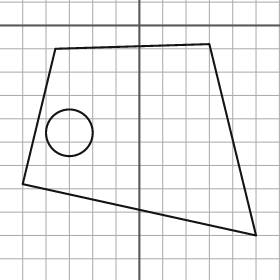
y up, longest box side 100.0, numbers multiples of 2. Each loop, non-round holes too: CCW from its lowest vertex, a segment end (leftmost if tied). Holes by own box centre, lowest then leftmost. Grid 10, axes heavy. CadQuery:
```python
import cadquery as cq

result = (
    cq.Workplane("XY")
    .moveTo(50.0, -90.0)
    .lineTo(30.0, -8.0)
    .lineTo(-36.0, -10.0)
    .lineTo(-50.0, -68.0)
    .close()
    .moveTo(-30.0, -46.0)
    .circle(10.0)
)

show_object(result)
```